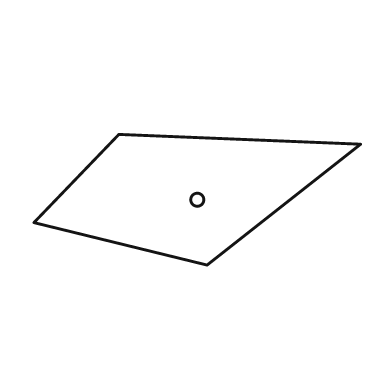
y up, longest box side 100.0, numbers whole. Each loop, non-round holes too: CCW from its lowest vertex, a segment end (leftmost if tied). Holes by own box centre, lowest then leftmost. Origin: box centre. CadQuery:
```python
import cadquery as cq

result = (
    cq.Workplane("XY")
    .moveTo(3.0, -20.0)
    .lineTo(50.0, 17.0)
    .lineTo(-24.0, 20.0)
    .lineTo(-50.0, -7.0)
    .close()
    .moveTo(0.0, 0.0)
    .circle(2.0)
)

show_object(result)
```